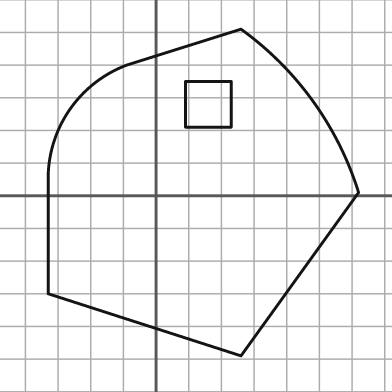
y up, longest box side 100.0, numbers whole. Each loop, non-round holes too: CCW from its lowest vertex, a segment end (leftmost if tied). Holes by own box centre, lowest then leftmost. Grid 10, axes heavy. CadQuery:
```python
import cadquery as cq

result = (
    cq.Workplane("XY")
    .moveTo(26.0, -49.0)
    .lineTo(62.0, 1.0)
    .threePointArc((48.0, 29.0), (26.0, 51.0))
    .lineTo(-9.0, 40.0)
    .threePointArc((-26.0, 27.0), (-33.0, 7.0))
    .lineTo(-33.0, -30.0)
    .close()
    .moveTo(9.0, 21.0)
    .lineTo(23.0, 21.0)
    .lineTo(23.0, 35.0)
    .lineTo(9.0, 35.0)
    .close()
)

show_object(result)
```